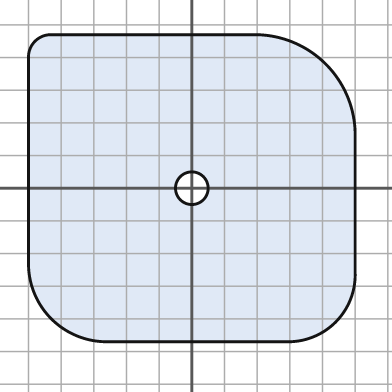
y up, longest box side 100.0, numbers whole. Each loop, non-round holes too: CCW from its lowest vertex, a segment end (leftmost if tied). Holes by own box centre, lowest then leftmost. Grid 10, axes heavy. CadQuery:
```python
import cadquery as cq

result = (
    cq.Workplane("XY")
    .moveTo(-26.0, -47.0)
    .lineTo(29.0, -47.0)
    .threePointArc((44.0, -41.0), (50.0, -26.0))
    .lineTo(50.0, 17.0)
    .threePointArc((41.0, 38.0), (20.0, 47.0))
    .lineTo(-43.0, 47.0)
    .threePointArc((-48.0, 45.0), (-50.0, 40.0))
    .lineTo(-50.0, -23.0)
    .threePointArc((-43.0, -40.0), (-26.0, -47.0))
    .close()
    .moveTo(0.0, 0.0)
    .circle(5.0)
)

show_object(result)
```